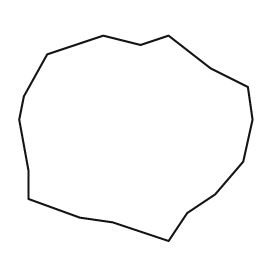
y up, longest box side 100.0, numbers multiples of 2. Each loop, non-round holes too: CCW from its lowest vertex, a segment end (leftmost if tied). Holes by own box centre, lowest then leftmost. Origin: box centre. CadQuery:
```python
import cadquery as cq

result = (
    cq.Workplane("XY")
    .moveTo(14.0, -44.0)
    .lineTo(22.0, -32.0)
    .lineTo(34.0, -24.0)
    .lineTo(46.0, -10.0)
    .lineTo(50.0, 8.0)
    .lineTo(48.0, 22.0)
    .lineTo(32.0, 30.0)
    .lineTo(14.0, 44.0)
    .lineTo(2.0, 40.0)
    .lineTo(-14.0, 44.0)
    .lineTo(-38.0, 36.0)
    .lineTo(-48.0, 18.0)
    .lineTo(-50.0, 8.0)
    .lineTo(-46.0, -14.0)
    .lineTo(-46.0, -26.0)
    .lineTo(-24.0, -34.0)
    .lineTo(-10.0, -36.0)
    .close()
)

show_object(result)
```